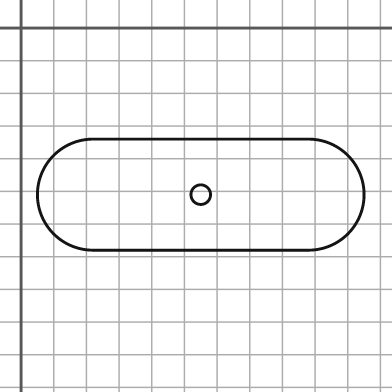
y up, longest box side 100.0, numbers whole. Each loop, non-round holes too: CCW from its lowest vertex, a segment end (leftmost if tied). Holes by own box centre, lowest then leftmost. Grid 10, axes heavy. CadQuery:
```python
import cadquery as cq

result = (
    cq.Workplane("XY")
    .moveTo(22.0, -68.0)
    .lineTo(88.0, -68.0)
    .threePointArc((105.0, -51.0), (88.0, -34.0))
    .lineTo(22.0, -34.0)
    .threePointArc((5.0, -51.0), (22.0, -68.0))
    .close()
    .moveTo(55.0, -51.0)
    .circle(3.0)
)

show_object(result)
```